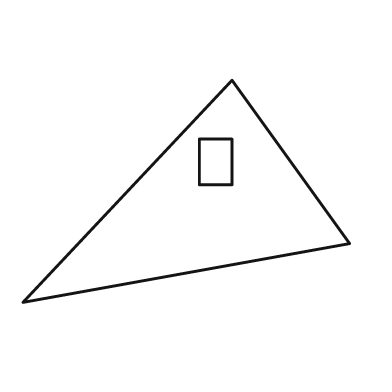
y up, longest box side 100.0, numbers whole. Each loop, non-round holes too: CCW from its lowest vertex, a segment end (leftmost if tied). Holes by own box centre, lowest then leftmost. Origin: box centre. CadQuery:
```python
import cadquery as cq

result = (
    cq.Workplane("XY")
    .moveTo(-50.0, -34.0)
    .lineTo(50.0, -16.0)
    .lineTo(14.0, 34.0)
    .close()
    .moveTo(4.0, 2.0)
    .lineTo(14.0, 2.0)
    .lineTo(14.0, 16.0)
    .lineTo(4.0, 16.0)
    .close()
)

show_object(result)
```